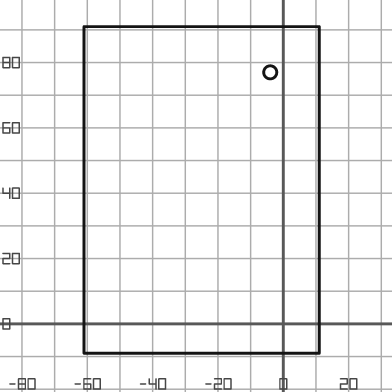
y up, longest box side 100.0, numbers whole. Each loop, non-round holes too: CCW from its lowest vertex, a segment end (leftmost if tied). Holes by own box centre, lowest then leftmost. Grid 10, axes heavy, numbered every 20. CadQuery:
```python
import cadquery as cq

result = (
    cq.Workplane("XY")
    .moveTo(-61.0, -9.0)
    .lineTo(11.0, -9.0)
    .lineTo(11.0, 91.0)
    .lineTo(-61.0, 91.0)
    .close()
    .moveTo(-4.0, 77.0)
    .circle(2.0)
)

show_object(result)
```